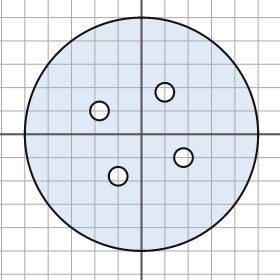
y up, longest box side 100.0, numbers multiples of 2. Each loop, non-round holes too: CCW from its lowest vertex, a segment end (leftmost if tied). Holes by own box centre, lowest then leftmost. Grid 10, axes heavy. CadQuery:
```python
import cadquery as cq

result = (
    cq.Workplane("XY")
    .moveTo(0.0, 0.0)
    .circle(50.0)
    .moveTo(-10.0, -18.0)
    .circle(4.0)
    .moveTo(18.0, -10.0)
    .circle(4.0)
    .moveTo(-18.0, 10.0)
    .circle(4.0)
    .moveTo(10.0, 18.0)
    .circle(4.0)
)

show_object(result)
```